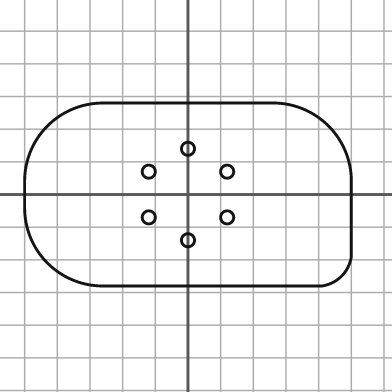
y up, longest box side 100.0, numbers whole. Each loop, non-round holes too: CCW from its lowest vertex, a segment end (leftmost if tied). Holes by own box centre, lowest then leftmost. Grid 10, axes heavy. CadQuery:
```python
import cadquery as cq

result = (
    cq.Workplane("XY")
    .moveTo(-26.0, -28.0)
    .lineTo(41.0, -28.0)
    .threePointArc((47.0, -25.0), (50.0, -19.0))
    .lineTo(50.0, 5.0)
    .threePointArc((43.0, 21.0), (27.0, 28.0))
    .lineTo(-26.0, 28.0)
    .threePointArc((-43.0, 21.0), (-50.0, 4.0))
    .lineTo(-50.0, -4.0)
    .threePointArc((-43.0, -21.0), (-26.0, -28.0))
    .close()
    .moveTo(0.0, -14.0)
    .circle(2.0)
    .moveTo(-12.0, -7.0)
    .circle(2.0)
    .moveTo(12.0, -7.0)
    .circle(2.0)
    .moveTo(-12.0, 7.0)
    .circle(2.0)
    .moveTo(12.0, 7.0)
    .circle(2.0)
    .moveTo(0.0, 14.0)
    .circle(2.0)
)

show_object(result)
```